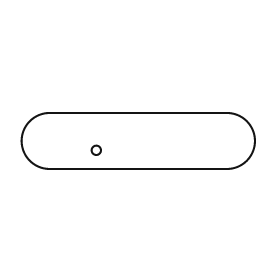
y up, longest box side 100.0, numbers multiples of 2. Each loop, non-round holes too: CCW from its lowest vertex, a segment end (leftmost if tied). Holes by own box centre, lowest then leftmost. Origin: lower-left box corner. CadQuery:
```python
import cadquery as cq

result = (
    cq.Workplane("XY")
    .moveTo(12.0, 0.0)
    .lineTo(88.0, 0.0)
    .threePointArc((100.0, 12.0), (88.0, 24.0))
    .lineTo(12.0, 24.0)
    .threePointArc((0.0, 12.0), (12.0, 0.0))
    .close()
    .moveTo(32.0, 8.0)
    .circle(2.0)
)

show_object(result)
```